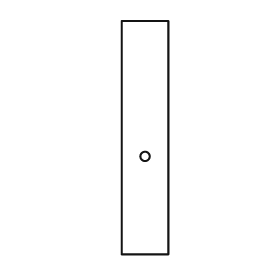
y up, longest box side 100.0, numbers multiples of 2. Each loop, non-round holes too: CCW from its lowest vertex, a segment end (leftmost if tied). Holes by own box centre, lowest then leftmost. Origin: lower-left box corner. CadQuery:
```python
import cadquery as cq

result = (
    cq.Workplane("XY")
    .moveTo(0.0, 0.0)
    .lineTo(20.0, 0.0)
    .lineTo(20.0, 100.0)
    .lineTo(0.0, 100.0)
    .close()
    .moveTo(10.0, 42.0)
    .circle(2.0)
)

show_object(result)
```